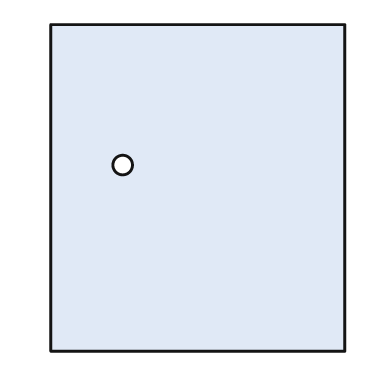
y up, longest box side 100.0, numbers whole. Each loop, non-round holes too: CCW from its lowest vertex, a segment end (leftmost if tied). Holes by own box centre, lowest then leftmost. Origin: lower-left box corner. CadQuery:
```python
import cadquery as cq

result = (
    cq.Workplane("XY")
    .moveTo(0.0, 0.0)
    .lineTo(90.0, 0.0)
    .lineTo(90.0, 100.0)
    .lineTo(0.0, 100.0)
    .close()
    .moveTo(22.0, 57.0)
    .circle(3.0)
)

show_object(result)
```